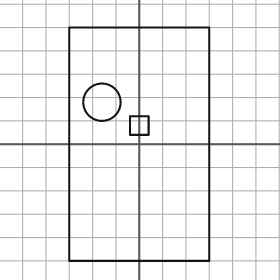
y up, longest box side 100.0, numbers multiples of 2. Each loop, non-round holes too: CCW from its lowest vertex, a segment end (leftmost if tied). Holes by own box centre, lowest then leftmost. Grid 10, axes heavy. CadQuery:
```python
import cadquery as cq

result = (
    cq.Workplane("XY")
    .moveTo(-30.0, -50.0)
    .lineTo(30.0, -50.0)
    .lineTo(30.0, 50.0)
    .lineTo(-30.0, 50.0)
    .close()
    .moveTo(-4.0, 4.0)
    .lineTo(4.0, 4.0)
    .lineTo(4.0, 12.0)
    .lineTo(-4.0, 12.0)
    .close()
    .moveTo(-16.0, 18.0)
    .circle(8.0)
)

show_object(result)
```